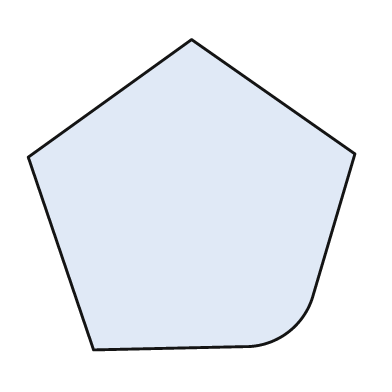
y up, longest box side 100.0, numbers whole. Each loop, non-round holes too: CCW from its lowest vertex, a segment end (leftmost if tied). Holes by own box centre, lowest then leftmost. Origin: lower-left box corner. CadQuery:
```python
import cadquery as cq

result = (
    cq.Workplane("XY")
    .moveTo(20.0, 0.0)
    .lineTo(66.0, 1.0)
    .threePointArc((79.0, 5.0), (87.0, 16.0))
    .lineTo(100.0, 60.0)
    .lineTo(50.0, 95.0)
    .lineTo(0.0, 59.0)
    .close()
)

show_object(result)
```